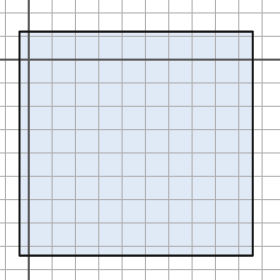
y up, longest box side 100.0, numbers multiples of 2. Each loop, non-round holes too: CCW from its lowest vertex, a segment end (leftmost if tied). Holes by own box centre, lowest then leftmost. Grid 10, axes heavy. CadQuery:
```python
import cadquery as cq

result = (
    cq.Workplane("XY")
    .moveTo(-4.0, -84.0)
    .lineTo(96.0, -84.0)
    .lineTo(96.0, 12.0)
    .lineTo(-4.0, 12.0)
    .close()
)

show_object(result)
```